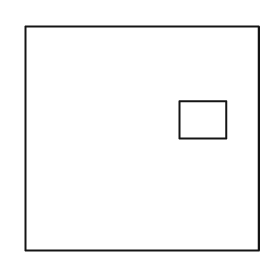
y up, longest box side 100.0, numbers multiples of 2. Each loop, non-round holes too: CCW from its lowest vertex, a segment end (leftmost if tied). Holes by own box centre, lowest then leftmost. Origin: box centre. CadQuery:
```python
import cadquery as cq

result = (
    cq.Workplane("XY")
    .moveTo(-50.0, -48.0)
    .lineTo(50.0, -48.0)
    .lineTo(50.0, 48.0)
    .lineTo(-50.0, 48.0)
    .close()
    .moveTo(16.0, 0.0)
    .lineTo(36.0, 0.0)
    .lineTo(36.0, 16.0)
    .lineTo(16.0, 16.0)
    .close()
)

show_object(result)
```